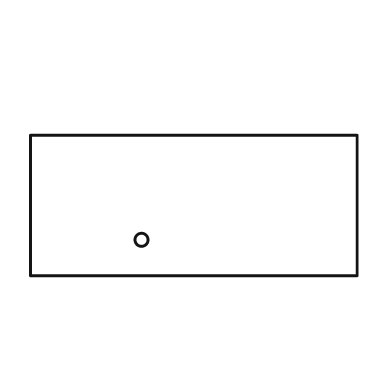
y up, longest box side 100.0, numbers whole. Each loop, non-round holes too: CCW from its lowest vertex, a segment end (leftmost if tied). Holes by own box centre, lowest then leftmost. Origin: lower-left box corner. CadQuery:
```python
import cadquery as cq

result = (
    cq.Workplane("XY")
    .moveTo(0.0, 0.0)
    .lineTo(100.0, 0.0)
    .lineTo(100.0, 43.0)
    .lineTo(0.0, 43.0)
    .close()
    .moveTo(34.0, 11.0)
    .circle(2.0)
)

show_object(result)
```